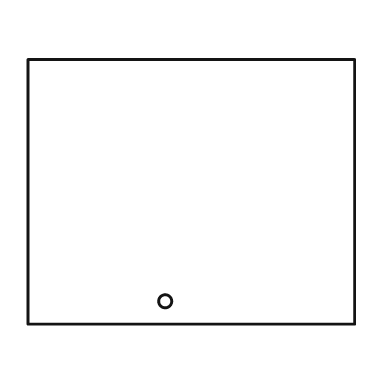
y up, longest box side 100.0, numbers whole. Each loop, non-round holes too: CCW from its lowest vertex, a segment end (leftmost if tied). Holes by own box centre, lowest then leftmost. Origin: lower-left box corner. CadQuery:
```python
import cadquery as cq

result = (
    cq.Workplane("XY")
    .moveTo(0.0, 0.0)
    .lineTo(100.0, 0.0)
    .lineTo(100.0, 81.0)
    .lineTo(0.0, 81.0)
    .close()
    .moveTo(42.0, 7.0)
    .circle(2.0)
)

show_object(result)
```